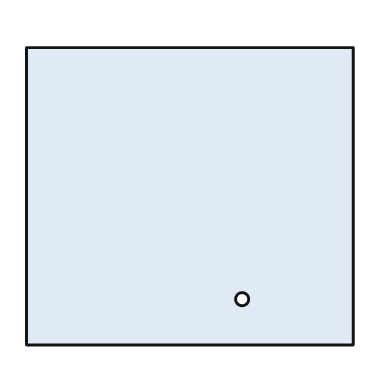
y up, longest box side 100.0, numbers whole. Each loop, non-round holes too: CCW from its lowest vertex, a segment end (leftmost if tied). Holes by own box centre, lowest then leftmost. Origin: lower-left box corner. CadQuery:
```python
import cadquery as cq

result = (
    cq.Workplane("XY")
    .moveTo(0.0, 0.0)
    .lineTo(100.0, 0.0)
    .lineTo(100.0, 91.0)
    .lineTo(0.0, 91.0)
    .close()
    .moveTo(66.0, 14.0)
    .circle(2.0)
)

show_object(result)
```